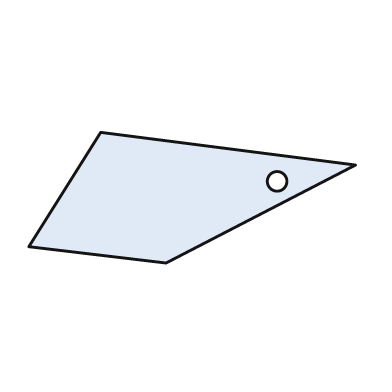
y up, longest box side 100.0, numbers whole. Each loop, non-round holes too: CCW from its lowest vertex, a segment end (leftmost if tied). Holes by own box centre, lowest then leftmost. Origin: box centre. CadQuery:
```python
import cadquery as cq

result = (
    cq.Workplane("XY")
    .moveTo(-8.0, -20.0)
    .lineTo(50.0, 10.0)
    .lineTo(-28.0, 20.0)
    .lineTo(-50.0, -15.0)
    .close()
    .moveTo(26.0, 5.0)
    .circle(3.0)
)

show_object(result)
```